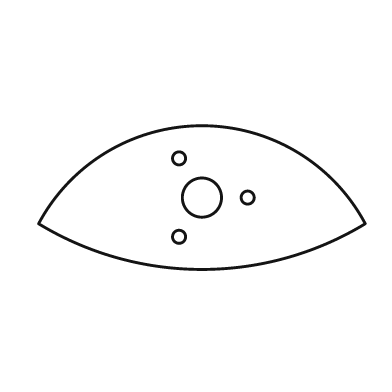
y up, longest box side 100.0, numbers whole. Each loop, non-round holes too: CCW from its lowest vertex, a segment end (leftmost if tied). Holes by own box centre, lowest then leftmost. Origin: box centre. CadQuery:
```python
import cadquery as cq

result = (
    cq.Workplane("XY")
    .moveTo(-50.0, -8.0)
    .threePointArc((0.0, -22.0), (50.0, -8.0))
    .threePointArc((0.0, 22.0), (-50.0, -8.0))
    .close()
    .moveTo(-7.0, -12.0)
    .circle(2.0)
    .moveTo(0.0, 0.0)
    .circle(6.0)
    .moveTo(14.0, 0.0)
    .circle(2.0)
    .moveTo(-7.0, 12.0)
    .circle(2.0)
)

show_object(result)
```